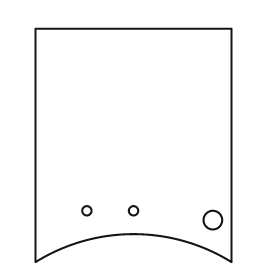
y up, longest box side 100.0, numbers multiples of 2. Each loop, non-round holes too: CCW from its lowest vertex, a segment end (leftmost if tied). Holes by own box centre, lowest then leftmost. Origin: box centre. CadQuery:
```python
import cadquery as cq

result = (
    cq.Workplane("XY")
    .moveTo(-42.0, -50.0)
    .threePointArc((0.0, -38.0), (42.0, -50.0))
    .lineTo(42.0, 50.0)
    .lineTo(-42.0, 50.0)
    .close()
    .moveTo(34.0, -32.0)
    .circle(4.0)
    .moveTo(-20.0, -28.0)
    .circle(2.0)
    .moveTo(0.0, -28.0)
    .circle(2.0)
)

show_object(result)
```